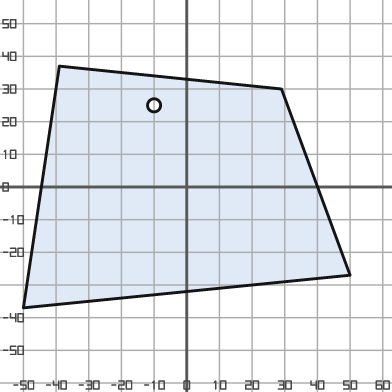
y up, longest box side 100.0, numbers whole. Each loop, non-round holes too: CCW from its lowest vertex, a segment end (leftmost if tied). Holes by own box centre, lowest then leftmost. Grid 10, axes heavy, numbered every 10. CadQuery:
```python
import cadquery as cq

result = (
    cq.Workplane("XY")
    .moveTo(-50.0, -37.0)
    .lineTo(50.0, -27.0)
    .lineTo(29.0, 30.0)
    .lineTo(-39.0, 37.0)
    .close()
    .moveTo(-10.0, 25.0)
    .circle(2.0)
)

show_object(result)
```